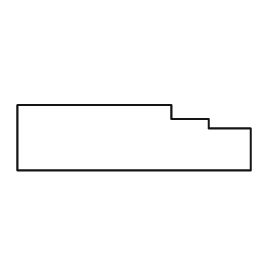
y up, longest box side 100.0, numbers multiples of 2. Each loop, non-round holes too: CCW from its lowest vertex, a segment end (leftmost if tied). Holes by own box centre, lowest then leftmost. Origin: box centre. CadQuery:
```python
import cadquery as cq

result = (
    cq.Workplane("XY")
    .moveTo(-50.0, -14.0)
    .lineTo(50.0, -14.0)
    .lineTo(50.0, 4.0)
    .lineTo(32.0, 4.0)
    .lineTo(32.0, 8.0)
    .lineTo(16.0, 8.0)
    .lineTo(16.0, 14.0)
    .lineTo(-50.0, 14.0)
    .close()
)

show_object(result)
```